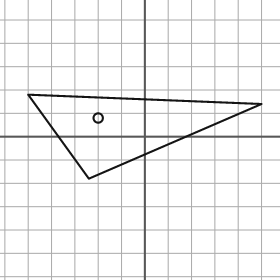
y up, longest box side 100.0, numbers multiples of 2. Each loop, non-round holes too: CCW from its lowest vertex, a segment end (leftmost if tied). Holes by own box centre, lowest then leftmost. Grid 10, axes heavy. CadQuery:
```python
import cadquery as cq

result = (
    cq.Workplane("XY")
    .moveTo(-24.0, -18.0)
    .lineTo(50.0, 14.0)
    .lineTo(-50.0, 18.0)
    .close()
    .moveTo(-20.0, 8.0)
    .circle(2.0)
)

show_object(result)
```